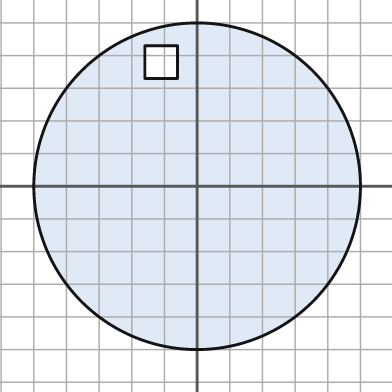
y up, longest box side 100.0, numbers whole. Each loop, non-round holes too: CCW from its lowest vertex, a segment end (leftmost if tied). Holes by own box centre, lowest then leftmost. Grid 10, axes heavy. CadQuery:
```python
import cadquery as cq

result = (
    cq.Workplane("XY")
    .moveTo(0.0, 0.0)
    .circle(50.0)
    .moveTo(-16.0, 33.0)
    .lineTo(-6.0, 33.0)
    .lineTo(-6.0, 43.0)
    .lineTo(-16.0, 43.0)
    .close()
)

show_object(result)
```